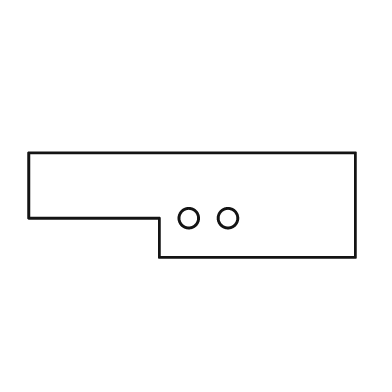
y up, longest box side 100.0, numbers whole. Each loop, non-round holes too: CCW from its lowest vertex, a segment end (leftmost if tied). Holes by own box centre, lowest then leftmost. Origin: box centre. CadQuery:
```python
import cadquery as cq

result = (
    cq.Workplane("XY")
    .moveTo(-10.0, -16.0)
    .lineTo(50.0, -16.0)
    .lineTo(50.0, 16.0)
    .lineTo(-50.0, 16.0)
    .lineTo(-50.0, -4.0)
    .lineTo(-10.0, -4.0)
    .close()
    .moveTo(-1.0, -4.0)
    .circle(3.0)
    .moveTo(11.0, -4.0)
    .circle(3.0)
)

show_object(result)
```